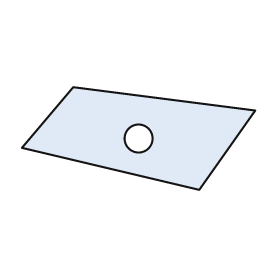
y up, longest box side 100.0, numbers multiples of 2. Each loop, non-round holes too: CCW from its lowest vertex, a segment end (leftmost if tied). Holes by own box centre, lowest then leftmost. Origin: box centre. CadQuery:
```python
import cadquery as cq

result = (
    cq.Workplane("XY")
    .moveTo(26.0, -22.0)
    .lineTo(50.0, 12.0)
    .lineTo(-28.0, 22.0)
    .lineTo(-50.0, -4.0)
    .close()
    .moveTo(0.0, 0.0)
    .circle(6.0)
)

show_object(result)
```